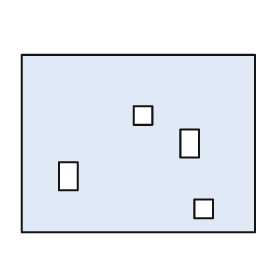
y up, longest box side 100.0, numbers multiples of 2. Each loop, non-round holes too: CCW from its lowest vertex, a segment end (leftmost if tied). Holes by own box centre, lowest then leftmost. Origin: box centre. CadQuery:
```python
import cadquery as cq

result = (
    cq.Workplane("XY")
    .moveTo(-50.0, -38.0)
    .lineTo(50.0, -38.0)
    .lineTo(50.0, 38.0)
    .lineTo(-50.0, 38.0)
    .close()
    .moveTo(24.0, -32.0)
    .lineTo(32.0, -32.0)
    .lineTo(32.0, -24.0)
    .lineTo(24.0, -24.0)
    .close()
    .moveTo(-34.0, -20.0)
    .lineTo(-26.0, -20.0)
    .lineTo(-26.0, -8.0)
    .lineTo(-34.0, -8.0)
    .close()
    .moveTo(18.0, -6.0)
    .lineTo(26.0, -6.0)
    .lineTo(26.0, 6.0)
    .lineTo(18.0, 6.0)
    .close()
    .moveTo(-2.0, 8.0)
    .lineTo(6.0, 8.0)
    .lineTo(6.0, 16.0)
    .lineTo(-2.0, 16.0)
    .close()
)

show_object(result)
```